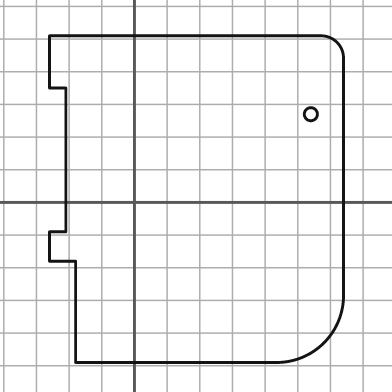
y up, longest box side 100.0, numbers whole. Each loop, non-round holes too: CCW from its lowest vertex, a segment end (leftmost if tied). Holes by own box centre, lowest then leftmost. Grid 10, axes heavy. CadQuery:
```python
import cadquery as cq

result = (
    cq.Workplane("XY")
    .moveTo(-18.0, -49.0)
    .lineTo(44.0, -49.0)
    .threePointArc((58.0, -43.0), (64.0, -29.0))
    .lineTo(64.0, 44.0)
    .threePointArc((62.0, 49.0), (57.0, 51.0))
    .lineTo(-26.0, 51.0)
    .lineTo(-26.0, 35.0)
    .lineTo(-21.0, 35.0)
    .lineTo(-21.0, -9.0)
    .lineTo(-26.0, -9.0)
    .lineTo(-26.0, -18.0)
    .lineTo(-18.0, -18.0)
    .close()
    .moveTo(54.0, 27.0)
    .circle(2.0)
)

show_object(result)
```